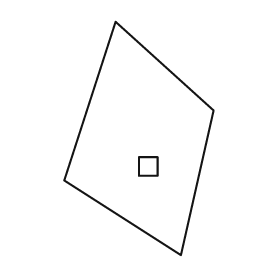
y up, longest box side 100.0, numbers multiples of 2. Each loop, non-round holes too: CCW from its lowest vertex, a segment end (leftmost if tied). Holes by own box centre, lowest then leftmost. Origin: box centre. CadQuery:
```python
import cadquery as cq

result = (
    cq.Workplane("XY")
    .moveTo(18.0, -50.0)
    .lineTo(32.0, 12.0)
    .lineTo(-10.0, 50.0)
    .lineTo(-32.0, -18.0)
    .close()
    .moveTo(0.0, -16.0)
    .lineTo(8.0, -16.0)
    .lineTo(8.0, -8.0)
    .lineTo(0.0, -8.0)
    .close()
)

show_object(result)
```